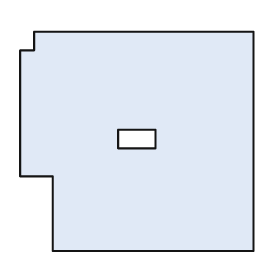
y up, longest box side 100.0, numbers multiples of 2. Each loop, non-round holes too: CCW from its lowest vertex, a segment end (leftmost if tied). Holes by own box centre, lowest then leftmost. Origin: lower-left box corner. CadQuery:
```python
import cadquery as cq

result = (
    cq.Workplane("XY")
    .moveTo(14.0, 0.0)
    .lineTo(100.0, 0.0)
    .lineTo(100.0, 94.0)
    .lineTo(6.0, 94.0)
    .lineTo(6.0, 86.0)
    .lineTo(0.0, 86.0)
    .lineTo(0.0, 32.0)
    .lineTo(14.0, 32.0)
    .close()
    .moveTo(42.0, 44.0)
    .lineTo(58.0, 44.0)
    .lineTo(58.0, 52.0)
    .lineTo(42.0, 52.0)
    .close()
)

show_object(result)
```